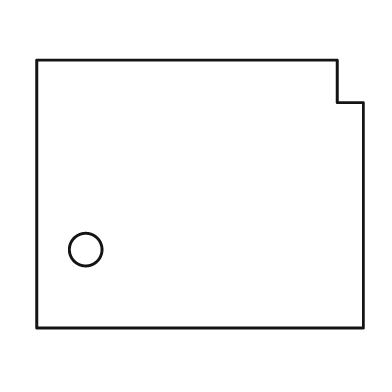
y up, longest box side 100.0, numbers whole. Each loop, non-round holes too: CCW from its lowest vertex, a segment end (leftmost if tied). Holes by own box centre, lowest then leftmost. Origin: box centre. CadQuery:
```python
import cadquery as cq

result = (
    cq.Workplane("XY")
    .moveTo(-50.0, -41.0)
    .lineTo(50.0, -41.0)
    .lineTo(50.0, 28.0)
    .lineTo(42.0, 28.0)
    .lineTo(42.0, 41.0)
    .lineTo(-50.0, 41.0)
    .close()
    .moveTo(-35.0, -17.0)
    .circle(5.0)
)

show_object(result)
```